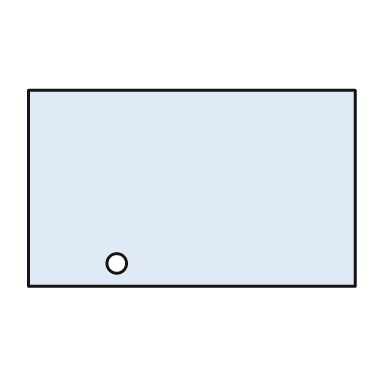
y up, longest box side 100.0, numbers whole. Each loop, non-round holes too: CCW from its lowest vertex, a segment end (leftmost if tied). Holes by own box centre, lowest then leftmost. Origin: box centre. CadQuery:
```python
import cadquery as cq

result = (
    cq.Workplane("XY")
    .moveTo(-50.0, -30.0)
    .lineTo(50.0, -30.0)
    .lineTo(50.0, 30.0)
    .lineTo(-50.0, 30.0)
    .close()
    .moveTo(-23.0, -23.0)
    .circle(3.0)
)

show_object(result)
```